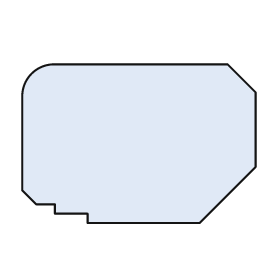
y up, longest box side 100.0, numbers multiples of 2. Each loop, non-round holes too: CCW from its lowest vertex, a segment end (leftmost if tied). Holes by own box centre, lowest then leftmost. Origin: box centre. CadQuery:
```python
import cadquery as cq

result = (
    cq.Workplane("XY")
    .moveTo(-22.0, -34.0)
    .lineTo(26.0, -34.0)
    .lineTo(50.0, -10.0)
    .lineTo(50.0, 22.0)
    .lineTo(38.0, 34.0)
    .lineTo(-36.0, 34.0)
    .threePointArc((-46.0, 30.0), (-50.0, 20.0))
    .lineTo(-50.0, -20.0)
    .lineTo(-44.0, -26.0)
    .lineTo(-36.0, -26.0)
    .lineTo(-36.0, -30.0)
    .lineTo(-22.0, -30.0)
    .close()
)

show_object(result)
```